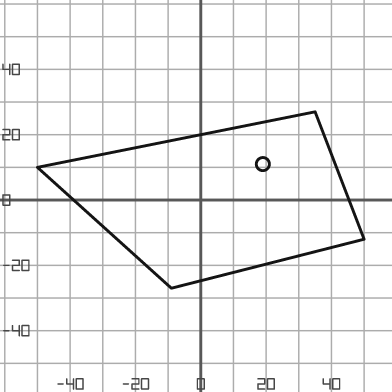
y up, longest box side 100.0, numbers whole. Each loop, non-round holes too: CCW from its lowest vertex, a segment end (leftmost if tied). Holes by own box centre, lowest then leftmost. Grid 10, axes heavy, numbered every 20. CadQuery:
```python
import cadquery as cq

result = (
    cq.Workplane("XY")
    .moveTo(-9.0, -27.0)
    .lineTo(50.0, -12.0)
    .lineTo(35.0, 27.0)
    .lineTo(-50.0, 10.0)
    .close()
    .moveTo(19.0, 11.0)
    .circle(2.0)
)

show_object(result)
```